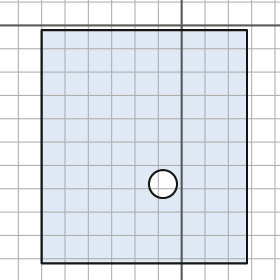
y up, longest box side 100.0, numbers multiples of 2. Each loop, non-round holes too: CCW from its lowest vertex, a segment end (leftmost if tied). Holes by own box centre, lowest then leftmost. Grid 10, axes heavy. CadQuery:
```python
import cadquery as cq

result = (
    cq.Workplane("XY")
    .moveTo(-60.0, -102.0)
    .lineTo(28.0, -102.0)
    .lineTo(28.0, -2.0)
    .lineTo(-60.0, -2.0)
    .close()
    .moveTo(-8.0, -68.0)
    .circle(6.0)
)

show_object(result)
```